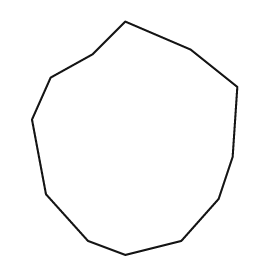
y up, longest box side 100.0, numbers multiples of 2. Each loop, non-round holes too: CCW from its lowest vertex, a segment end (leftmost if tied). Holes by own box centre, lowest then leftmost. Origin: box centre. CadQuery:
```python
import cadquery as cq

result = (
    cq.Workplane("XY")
    .moveTo(-4.0, -50.0)
    .lineTo(20.0, -44.0)
    .lineTo(36.0, -26.0)
    .lineTo(42.0, -8.0)
    .lineTo(44.0, 22.0)
    .lineTo(24.0, 38.0)
    .lineTo(-4.0, 50.0)
    .lineTo(-18.0, 36.0)
    .lineTo(-36.0, 26.0)
    .lineTo(-44.0, 8.0)
    .lineTo(-38.0, -24.0)
    .lineTo(-20.0, -44.0)
    .close()
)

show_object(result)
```